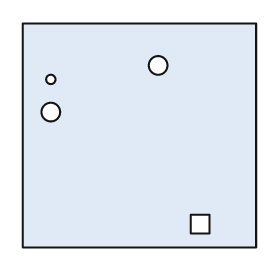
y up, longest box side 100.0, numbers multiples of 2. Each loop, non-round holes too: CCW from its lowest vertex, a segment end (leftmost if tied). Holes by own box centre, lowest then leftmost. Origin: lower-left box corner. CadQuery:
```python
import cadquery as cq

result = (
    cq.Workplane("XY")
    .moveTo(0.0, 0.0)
    .lineTo(100.0, 0.0)
    .lineTo(100.0, 96.0)
    .lineTo(0.0, 96.0)
    .close()
    .moveTo(72.0, 6.0)
    .lineTo(80.0, 6.0)
    .lineTo(80.0, 14.0)
    .lineTo(72.0, 14.0)
    .close()
    .moveTo(12.0, 58.0)
    .circle(4.0)
    .moveTo(12.0, 72.0)
    .circle(2.0)
    .moveTo(58.0, 78.0)
    .circle(4.0)
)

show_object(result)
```